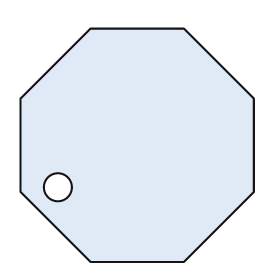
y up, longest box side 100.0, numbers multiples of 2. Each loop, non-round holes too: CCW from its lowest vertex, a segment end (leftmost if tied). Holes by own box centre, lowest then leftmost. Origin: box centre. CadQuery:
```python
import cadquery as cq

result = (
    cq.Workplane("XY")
    .moveTo(-20.0, -50.0)
    .lineTo(20.0, -50.0)
    .lineTo(50.0, -20.0)
    .lineTo(50.0, 20.0)
    .lineTo(20.0, 50.0)
    .lineTo(-20.0, 50.0)
    .lineTo(-50.0, 20.0)
    .lineTo(-50.0, -20.0)
    .close()
    .moveTo(-34.0, -18.0)
    .circle(6.0)
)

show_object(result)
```